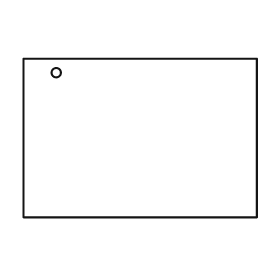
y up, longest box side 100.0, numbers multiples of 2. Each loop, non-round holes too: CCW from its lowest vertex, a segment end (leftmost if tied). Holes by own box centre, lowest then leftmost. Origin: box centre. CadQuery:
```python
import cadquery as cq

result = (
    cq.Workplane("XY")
    .moveTo(-50.0, -34.0)
    .lineTo(50.0, -34.0)
    .lineTo(50.0, 34.0)
    .lineTo(-50.0, 34.0)
    .close()
    .moveTo(-36.0, 28.0)
    .circle(2.0)
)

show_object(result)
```